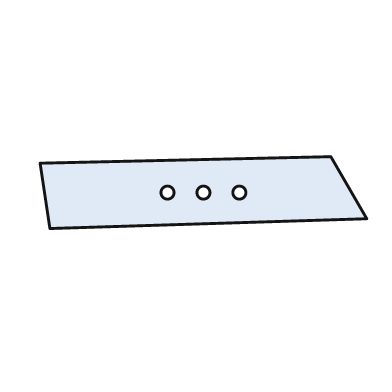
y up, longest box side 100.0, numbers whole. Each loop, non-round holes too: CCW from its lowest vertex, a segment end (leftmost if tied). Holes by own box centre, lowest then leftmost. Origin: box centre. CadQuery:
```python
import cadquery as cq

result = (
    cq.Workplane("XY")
    .moveTo(-47.0, -11.0)
    .lineTo(50.0, -8.0)
    .lineTo(39.0, 11.0)
    .lineTo(-50.0, 9.0)
    .close()
    .moveTo(-11.0, 0.0)
    .circle(2.0)
    .moveTo(0.0, 0.0)
    .circle(2.0)
    .moveTo(11.0, 0.0)
    .circle(2.0)
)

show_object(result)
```